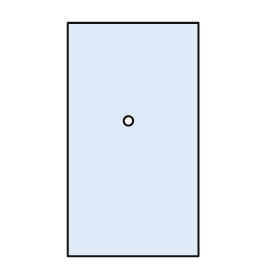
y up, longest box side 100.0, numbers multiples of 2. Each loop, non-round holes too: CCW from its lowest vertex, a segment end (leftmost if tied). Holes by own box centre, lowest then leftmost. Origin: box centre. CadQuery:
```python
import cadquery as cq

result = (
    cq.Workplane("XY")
    .moveTo(-28.0, -50.0)
    .lineTo(28.0, -50.0)
    .lineTo(28.0, 50.0)
    .lineTo(-28.0, 50.0)
    .close()
    .moveTo(-2.0, 8.0)
    .circle(2.0)
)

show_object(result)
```